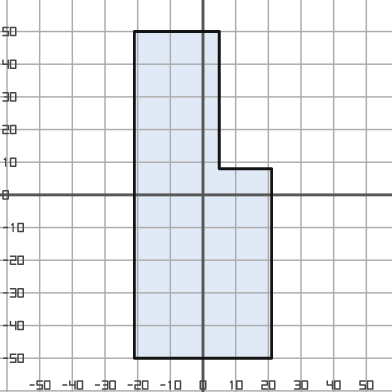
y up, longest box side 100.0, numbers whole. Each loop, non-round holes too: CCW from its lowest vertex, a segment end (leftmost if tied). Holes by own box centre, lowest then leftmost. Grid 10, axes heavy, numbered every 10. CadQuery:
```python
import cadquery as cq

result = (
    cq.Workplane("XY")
    .moveTo(-21.0, -50.0)
    .lineTo(21.0, -50.0)
    .lineTo(21.0, 8.0)
    .lineTo(5.0, 8.0)
    .lineTo(5.0, 50.0)
    .lineTo(-21.0, 50.0)
    .close()
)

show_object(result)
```